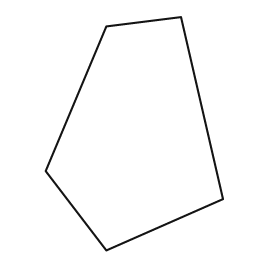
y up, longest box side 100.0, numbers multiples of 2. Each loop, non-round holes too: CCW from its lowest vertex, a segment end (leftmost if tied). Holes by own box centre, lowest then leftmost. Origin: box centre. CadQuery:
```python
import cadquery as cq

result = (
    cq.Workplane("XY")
    .moveTo(-12.0, -50.0)
    .lineTo(38.0, -28.0)
    .lineTo(20.0, 50.0)
    .lineTo(-12.0, 46.0)
    .lineTo(-38.0, -16.0)
    .close()
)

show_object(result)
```